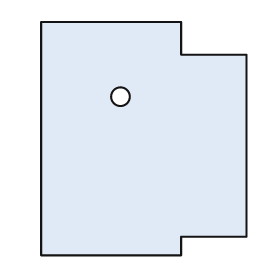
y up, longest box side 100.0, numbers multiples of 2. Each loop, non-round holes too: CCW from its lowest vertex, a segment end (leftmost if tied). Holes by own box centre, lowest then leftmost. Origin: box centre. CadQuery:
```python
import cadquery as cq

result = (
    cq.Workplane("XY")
    .moveTo(-44.0, -50.0)
    .lineTo(16.0, -50.0)
    .lineTo(16.0, -42.0)
    .lineTo(44.0, -42.0)
    .lineTo(44.0, 36.0)
    .lineTo(16.0, 36.0)
    .lineTo(16.0, 50.0)
    .lineTo(-44.0, 50.0)
    .close()
    .moveTo(-10.0, 18.0)
    .circle(4.0)
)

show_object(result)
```